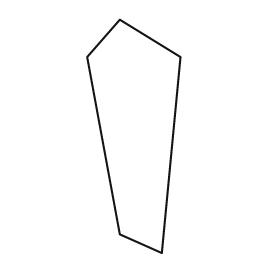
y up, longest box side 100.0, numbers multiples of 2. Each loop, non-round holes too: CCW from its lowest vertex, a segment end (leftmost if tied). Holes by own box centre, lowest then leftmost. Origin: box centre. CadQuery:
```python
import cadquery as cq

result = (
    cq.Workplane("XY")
    .moveTo(12.0, -50.0)
    .lineTo(20.0, 34.0)
    .lineTo(-6.0, 50.0)
    .lineTo(-20.0, 34.0)
    .lineTo(-6.0, -42.0)
    .close()
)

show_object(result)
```